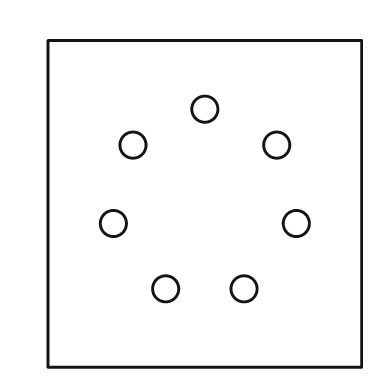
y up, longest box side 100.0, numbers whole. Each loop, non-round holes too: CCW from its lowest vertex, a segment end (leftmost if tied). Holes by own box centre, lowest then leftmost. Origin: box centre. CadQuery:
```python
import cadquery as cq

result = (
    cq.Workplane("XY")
    .moveTo(-48.0, -50.0)
    .lineTo(48.0, -50.0)
    .lineTo(48.0, 50.0)
    .lineTo(-48.0, 50.0)
    .close()
    .moveTo(-12.0, -26.0)
    .circle(4.0)
    .moveTo(12.0, -26.0)
    .circle(4.0)
    .moveTo(-28.0, -6.0)
    .circle(4.0)
    .moveTo(28.0, -6.0)
    .circle(4.0)
    .moveTo(-22.0, 18.0)
    .circle(4.0)
    .moveTo(22.0, 18.0)
    .circle(4.0)
    .moveTo(0.0, 29.0)
    .circle(4.0)
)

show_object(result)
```